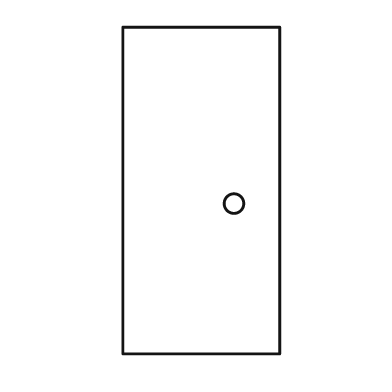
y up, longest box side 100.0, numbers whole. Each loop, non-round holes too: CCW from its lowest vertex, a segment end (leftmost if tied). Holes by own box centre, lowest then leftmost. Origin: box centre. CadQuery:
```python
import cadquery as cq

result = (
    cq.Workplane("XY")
    .moveTo(-24.0, -50.0)
    .lineTo(24.0, -50.0)
    .lineTo(24.0, 50.0)
    .lineTo(-24.0, 50.0)
    .close()
    .moveTo(10.0, -4.0)
    .circle(3.0)
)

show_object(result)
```